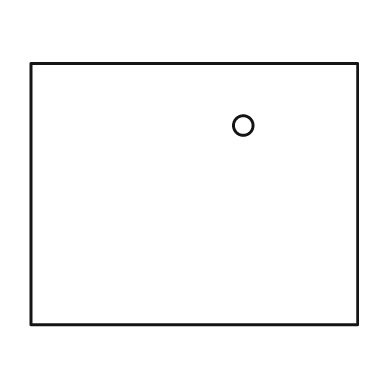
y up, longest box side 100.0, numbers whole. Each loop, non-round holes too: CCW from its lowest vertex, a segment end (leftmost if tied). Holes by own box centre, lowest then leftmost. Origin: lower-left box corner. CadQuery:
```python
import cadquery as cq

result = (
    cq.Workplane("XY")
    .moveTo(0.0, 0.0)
    .lineTo(100.0, 0.0)
    .lineTo(100.0, 80.0)
    .lineTo(0.0, 80.0)
    .close()
    .moveTo(65.0, 61.0)
    .circle(3.0)
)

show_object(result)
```